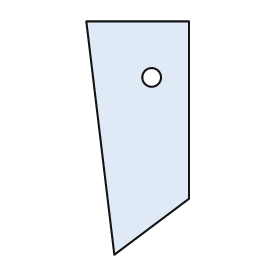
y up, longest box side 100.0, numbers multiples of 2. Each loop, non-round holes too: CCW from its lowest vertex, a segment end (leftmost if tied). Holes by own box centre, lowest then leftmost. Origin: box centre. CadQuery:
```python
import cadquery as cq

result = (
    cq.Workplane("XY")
    .moveTo(-10.0, -50.0)
    .lineTo(22.0, -26.0)
    .lineTo(22.0, 50.0)
    .lineTo(-22.0, 50.0)
    .close()
    .moveTo(6.0, 26.0)
    .circle(4.0)
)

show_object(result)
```